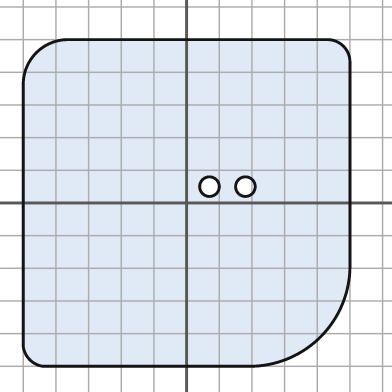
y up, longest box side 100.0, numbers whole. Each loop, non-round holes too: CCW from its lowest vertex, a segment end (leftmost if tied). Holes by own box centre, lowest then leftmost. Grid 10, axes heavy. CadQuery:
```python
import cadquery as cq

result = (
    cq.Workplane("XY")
    .moveTo(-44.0, -50.0)
    .lineTo(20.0, -50.0)
    .threePointArc((41.0, -41.0), (50.0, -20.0))
    .lineTo(50.0, 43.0)
    .threePointArc((48.0, 48.0), (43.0, 50.0))
    .lineTo(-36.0, 50.0)
    .threePointArc((-46.0, 46.0), (-50.0, 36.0))
    .lineTo(-50.0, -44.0)
    .threePointArc((-48.0, -48.0), (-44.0, -50.0))
    .close()
    .moveTo(7.0, 5.0)
    .circle(3.0)
    .moveTo(18.0, 5.0)
    .circle(3.0)
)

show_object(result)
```